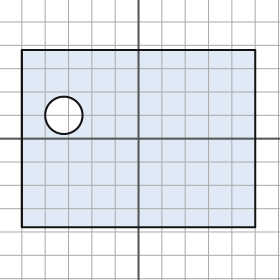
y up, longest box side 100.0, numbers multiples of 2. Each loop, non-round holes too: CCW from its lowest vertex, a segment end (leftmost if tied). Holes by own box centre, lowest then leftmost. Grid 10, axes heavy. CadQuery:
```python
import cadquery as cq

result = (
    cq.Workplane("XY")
    .moveTo(-50.0, -38.0)
    .lineTo(50.0, -38.0)
    .lineTo(50.0, 38.0)
    .lineTo(-50.0, 38.0)
    .close()
    .moveTo(-32.0, 10.0)
    .circle(8.0)
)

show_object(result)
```